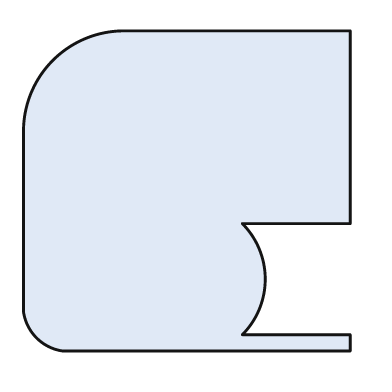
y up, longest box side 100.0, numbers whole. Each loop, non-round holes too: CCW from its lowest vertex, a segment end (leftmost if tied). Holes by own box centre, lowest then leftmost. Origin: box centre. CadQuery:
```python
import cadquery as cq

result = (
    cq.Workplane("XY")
    .moveTo(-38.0, -49.0)
    .lineTo(50.0, -49.0)
    .lineTo(50.0, -44.0)
    .lineTo(17.0, -44.0)
    .threePointArc((24.0, -27.0), (17.0, -10.0))
    .lineTo(50.0, -10.0)
    .lineTo(50.0, 49.0)
    .lineTo(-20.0, 49.0)
    .threePointArc((-41.0, 40.0), (-50.0, 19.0))
    .lineTo(-50.0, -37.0)
    .threePointArc((-46.0, -45.0), (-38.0, -49.0))
    .close()
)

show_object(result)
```